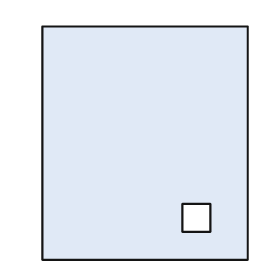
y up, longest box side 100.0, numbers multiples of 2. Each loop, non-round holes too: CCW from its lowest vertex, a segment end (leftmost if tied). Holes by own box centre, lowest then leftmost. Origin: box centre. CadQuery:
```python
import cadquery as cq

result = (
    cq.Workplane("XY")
    .moveTo(-44.0, -50.0)
    .lineTo(44.0, -50.0)
    .lineTo(44.0, 50.0)
    .lineTo(-44.0, 50.0)
    .close()
    .moveTo(16.0, -38.0)
    .lineTo(28.0, -38.0)
    .lineTo(28.0, -26.0)
    .lineTo(16.0, -26.0)
    .close()
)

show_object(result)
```